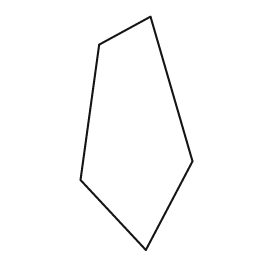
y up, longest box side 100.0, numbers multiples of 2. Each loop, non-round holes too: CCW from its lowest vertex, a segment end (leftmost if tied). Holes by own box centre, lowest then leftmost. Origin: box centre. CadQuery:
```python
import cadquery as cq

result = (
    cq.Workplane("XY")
    .moveTo(4.0, -50.0)
    .lineTo(24.0, -12.0)
    .lineTo(6.0, 50.0)
    .lineTo(-16.0, 38.0)
    .lineTo(-24.0, -20.0)
    .close()
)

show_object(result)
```